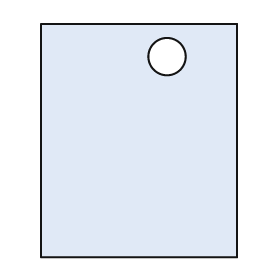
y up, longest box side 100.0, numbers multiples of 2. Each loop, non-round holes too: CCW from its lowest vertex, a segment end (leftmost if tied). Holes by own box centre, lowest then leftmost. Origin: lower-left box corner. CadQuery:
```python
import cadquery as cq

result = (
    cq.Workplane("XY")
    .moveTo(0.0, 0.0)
    .lineTo(84.0, 0.0)
    .lineTo(84.0, 100.0)
    .lineTo(0.0, 100.0)
    .close()
    .moveTo(54.0, 86.0)
    .circle(8.0)
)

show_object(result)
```